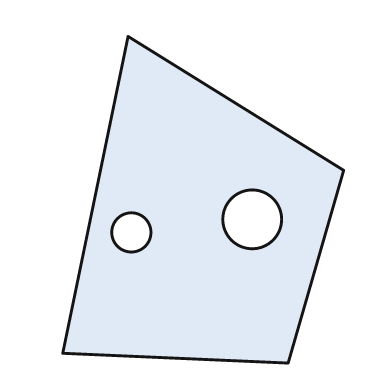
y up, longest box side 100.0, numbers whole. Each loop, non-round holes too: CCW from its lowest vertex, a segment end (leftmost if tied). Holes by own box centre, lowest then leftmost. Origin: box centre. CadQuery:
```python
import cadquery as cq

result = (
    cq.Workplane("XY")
    .moveTo(26.0, -50.0)
    .lineTo(43.0, 9.0)
    .lineTo(-23.0, 50.0)
    .lineTo(-43.0, -47.0)
    .close()
    .moveTo(-22.0, -10.0)
    .circle(6.0)
    .moveTo(15.0, -6.0)
    .circle(9.0)
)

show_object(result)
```